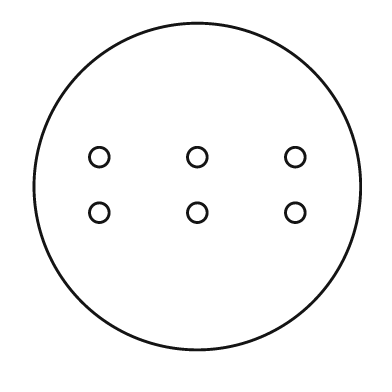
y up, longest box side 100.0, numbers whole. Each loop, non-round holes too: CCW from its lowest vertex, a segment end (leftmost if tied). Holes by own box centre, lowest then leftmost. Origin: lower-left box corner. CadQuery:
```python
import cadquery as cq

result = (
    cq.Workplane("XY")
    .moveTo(50.0, 50.0)
    .circle(50.0)
    .moveTo(20.0, 42.0)
    .circle(3.0)
    .moveTo(50.0, 42.0)
    .circle(3.0)
    .moveTo(80.0, 42.0)
    .circle(3.0)
    .moveTo(20.0, 59.0)
    .circle(3.0)
    .moveTo(50.0, 59.0)
    .circle(3.0)
    .moveTo(80.0, 59.0)
    .circle(3.0)
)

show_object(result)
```